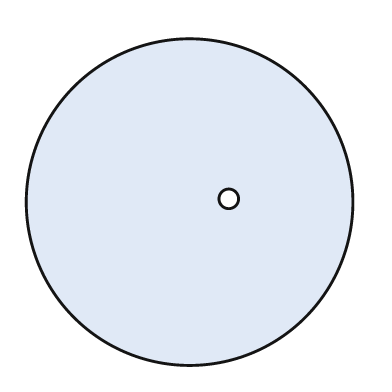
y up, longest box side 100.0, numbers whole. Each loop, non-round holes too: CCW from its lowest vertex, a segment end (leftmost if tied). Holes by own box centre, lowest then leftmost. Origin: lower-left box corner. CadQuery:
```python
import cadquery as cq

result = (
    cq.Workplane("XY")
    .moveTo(50.0, 50.0)
    .circle(50.0)
    .moveTo(62.0, 51.0)
    .circle(3.0)
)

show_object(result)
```